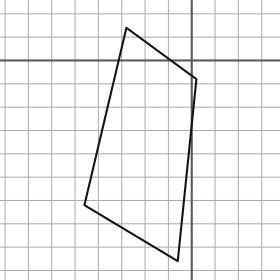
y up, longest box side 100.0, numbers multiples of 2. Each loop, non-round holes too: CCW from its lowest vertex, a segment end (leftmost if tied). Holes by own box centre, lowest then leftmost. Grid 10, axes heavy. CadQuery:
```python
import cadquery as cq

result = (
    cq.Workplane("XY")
    .moveTo(-6.0, -86.0)
    .lineTo(2.0, -8.0)
    .lineTo(-28.0, 14.0)
    .lineTo(-46.0, -62.0)
    .close()
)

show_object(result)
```